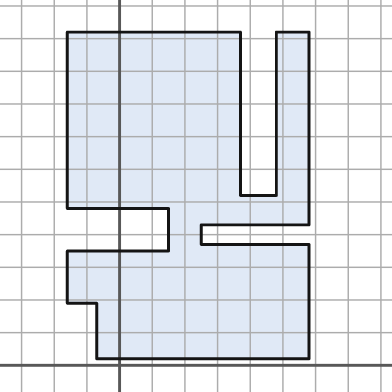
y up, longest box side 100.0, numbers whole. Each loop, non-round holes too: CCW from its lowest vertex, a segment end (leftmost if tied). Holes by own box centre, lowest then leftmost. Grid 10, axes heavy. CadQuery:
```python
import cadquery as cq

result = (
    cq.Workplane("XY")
    .moveTo(-7.0, 2.0)
    .lineTo(58.0, 2.0)
    .lineTo(58.0, 37.0)
    .lineTo(25.0, 37.0)
    .lineTo(25.0, 43.0)
    .lineTo(58.0, 43.0)
    .lineTo(58.0, 102.0)
    .lineTo(48.0, 102.0)
    .lineTo(48.0, 52.0)
    .lineTo(37.0, 52.0)
    .lineTo(37.0, 102.0)
    .lineTo(-16.0, 102.0)
    .lineTo(-16.0, 48.0)
    .lineTo(15.0, 48.0)
    .lineTo(15.0, 35.0)
    .lineTo(-16.0, 35.0)
    .lineTo(-16.0, 19.0)
    .lineTo(-7.0, 19.0)
    .close()
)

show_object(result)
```